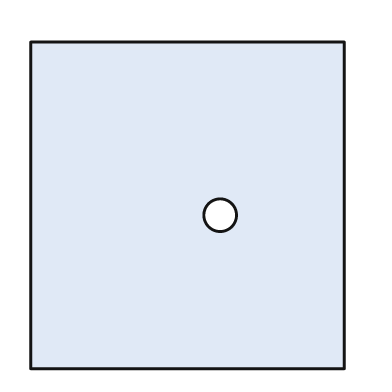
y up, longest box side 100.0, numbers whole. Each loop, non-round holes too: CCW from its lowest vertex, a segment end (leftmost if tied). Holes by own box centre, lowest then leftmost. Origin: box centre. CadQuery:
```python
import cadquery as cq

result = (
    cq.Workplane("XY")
    .moveTo(-48.0, -50.0)
    .lineTo(48.0, -50.0)
    .lineTo(48.0, 50.0)
    .lineTo(-48.0, 50.0)
    .close()
    .moveTo(10.0, -3.0)
    .circle(5.0)
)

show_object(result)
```